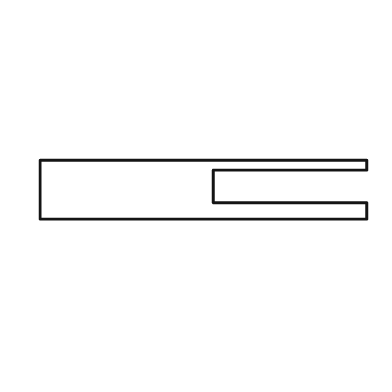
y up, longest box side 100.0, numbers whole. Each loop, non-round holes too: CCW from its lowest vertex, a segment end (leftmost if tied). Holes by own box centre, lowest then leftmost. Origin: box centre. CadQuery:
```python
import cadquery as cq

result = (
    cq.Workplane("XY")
    .moveTo(-50.0, -9.0)
    .lineTo(50.0, -9.0)
    .lineTo(50.0, -4.0)
    .lineTo(3.0, -4.0)
    .lineTo(3.0, 6.0)
    .lineTo(50.0, 6.0)
    .lineTo(50.0, 9.0)
    .lineTo(-50.0, 9.0)
    .close()
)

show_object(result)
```